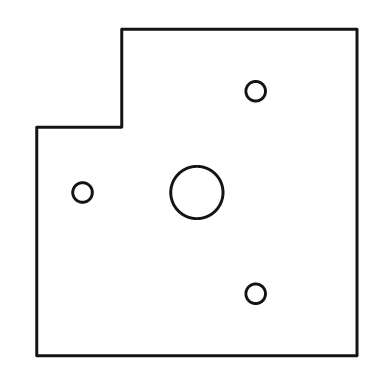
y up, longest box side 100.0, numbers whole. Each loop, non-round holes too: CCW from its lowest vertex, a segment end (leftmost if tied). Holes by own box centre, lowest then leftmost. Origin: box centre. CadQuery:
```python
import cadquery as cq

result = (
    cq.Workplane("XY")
    .moveTo(-49.0, -50.0)
    .lineTo(49.0, -50.0)
    .lineTo(49.0, 50.0)
    .lineTo(-23.0, 50.0)
    .lineTo(-23.0, 20.0)
    .lineTo(-49.0, 20.0)
    .close()
    .moveTo(18.0, -31.0)
    .circle(3.0)
    .moveTo(-35.0, 0.0)
    .circle(3.0)
    .moveTo(0.0, 0.0)
    .circle(8.0)
    .moveTo(18.0, 31.0)
    .circle(3.0)
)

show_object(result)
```